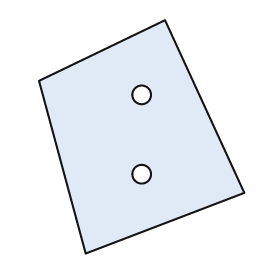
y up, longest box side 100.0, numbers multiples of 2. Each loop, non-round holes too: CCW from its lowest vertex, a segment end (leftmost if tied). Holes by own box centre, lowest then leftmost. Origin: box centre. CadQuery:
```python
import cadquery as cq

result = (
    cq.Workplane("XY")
    .moveTo(-24.0, -50.0)
    .lineTo(44.0, -24.0)
    .lineTo(10.0, 50.0)
    .lineTo(-44.0, 24.0)
    .close()
    .moveTo(0.0, -16.0)
    .circle(4.0)
    .moveTo(0.0, 18.0)
    .circle(4.0)
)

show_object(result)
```